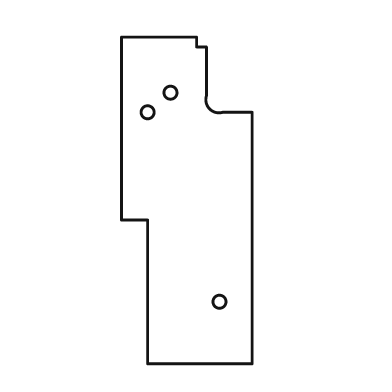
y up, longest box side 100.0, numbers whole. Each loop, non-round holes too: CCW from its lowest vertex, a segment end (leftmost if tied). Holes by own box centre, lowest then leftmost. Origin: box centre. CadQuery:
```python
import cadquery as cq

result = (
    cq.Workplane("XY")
    .moveTo(-12.0, -50.0)
    .lineTo(20.0, -50.0)
    .lineTo(20.0, 27.0)
    .lineTo(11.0, 27.0)
    .threePointArc((7.0, 28.0), (6.0, 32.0))
    .lineTo(6.0, 47.0)
    .lineTo(3.0, 47.0)
    .lineTo(3.0, 50.0)
    .lineTo(-20.0, 50.0)
    .lineTo(-20.0, -6.0)
    .lineTo(-12.0, -6.0)
    .close()
    .moveTo(10.0, -31.0)
    .circle(2.0)
    .moveTo(-12.0, 27.0)
    .circle(2.0)
    .moveTo(-5.0, 33.0)
    .circle(2.0)
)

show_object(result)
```